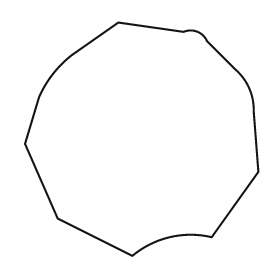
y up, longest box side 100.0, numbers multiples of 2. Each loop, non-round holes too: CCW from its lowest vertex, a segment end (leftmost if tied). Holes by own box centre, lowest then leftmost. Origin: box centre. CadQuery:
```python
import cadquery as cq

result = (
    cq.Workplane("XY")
    .moveTo(-4.0, -50.0)
    .threePointArc((12.0, -42.0), (30.0, -42.0))
    .lineTo(50.0, -14.0)
    .lineTo(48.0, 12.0)
    .threePointArc((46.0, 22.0), (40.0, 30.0))
    .lineTo(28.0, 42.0)
    .threePointArc((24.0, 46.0), (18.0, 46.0))
    .lineTo(-10.0, 50.0)
    .lineTo(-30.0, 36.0)
    .threePointArc((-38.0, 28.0), (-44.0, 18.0))
    .lineTo(-50.0, -2.0)
    .lineTo(-36.0, -34.0)
    .close()
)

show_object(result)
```